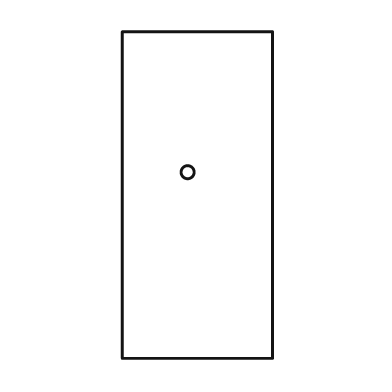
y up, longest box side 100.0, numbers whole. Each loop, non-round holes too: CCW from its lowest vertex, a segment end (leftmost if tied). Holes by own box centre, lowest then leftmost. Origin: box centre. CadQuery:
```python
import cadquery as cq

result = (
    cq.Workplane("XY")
    .moveTo(-23.0, -50.0)
    .lineTo(23.0, -50.0)
    .lineTo(23.0, 50.0)
    .lineTo(-23.0, 50.0)
    .close()
    .moveTo(-3.0, 7.0)
    .circle(2.0)
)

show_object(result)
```